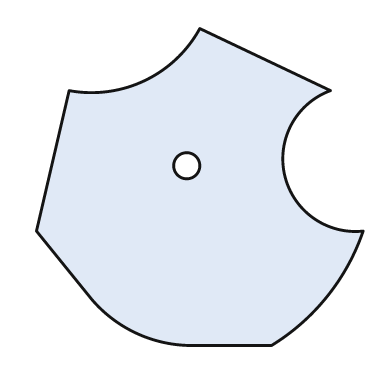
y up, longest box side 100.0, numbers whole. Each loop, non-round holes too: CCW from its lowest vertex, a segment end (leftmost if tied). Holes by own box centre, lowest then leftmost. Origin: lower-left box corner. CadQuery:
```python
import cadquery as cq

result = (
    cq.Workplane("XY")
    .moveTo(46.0, 0.0)
    .lineTo(72.0, 0.0)
    .threePointArc((89.0, 15.0), (100.0, 35.0))
    .threePointArc((76.0, 52.0), (90.0, 78.0))
    .lineTo(50.0, 97.0)
    .threePointArc((33.0, 81.0), (10.0, 78.0))
    .lineTo(0.0, 35.0)
    .lineTo(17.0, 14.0)
    .threePointArc((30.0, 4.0), (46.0, 0.0))
    .close()
    .moveTo(46.0, 55.0)
    .circle(4.0)
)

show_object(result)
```